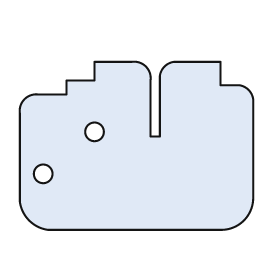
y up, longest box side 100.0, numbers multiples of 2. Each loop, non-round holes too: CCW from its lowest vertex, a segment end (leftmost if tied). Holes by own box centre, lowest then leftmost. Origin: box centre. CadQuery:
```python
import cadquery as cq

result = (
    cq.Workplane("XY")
    .moveTo(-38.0, -36.0)
    .lineTo(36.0, -36.0)
    .threePointArc((46.0, -32.0), (50.0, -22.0))
    .lineTo(50.0, 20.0)
    .threePointArc((48.0, 24.0), (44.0, 26.0))
    .lineTo(36.0, 26.0)
    .lineTo(36.0, 36.0)
    .lineTo(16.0, 36.0)
    .threePointArc((12.0, 34.0), (10.0, 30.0))
    .lineTo(10.0, 4.0)
    .lineTo(6.0, 4.0)
    .lineTo(6.0, 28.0)
    .threePointArc((4.0, 34.0), (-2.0, 36.0))
    .lineTo(-18.0, 36.0)
    .lineTo(-18.0, 28.0)
    .lineTo(-30.0, 28.0)
    .lineTo(-30.0, 22.0)
    .lineTo(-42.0, 22.0)
    .threePointArc((-48.0, 20.0), (-50.0, 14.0))
    .lineTo(-50.0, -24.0)
    .threePointArc((-46.0, -32.0), (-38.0, -36.0))
    .close()
    .moveTo(-40.0, -12.0)
    .circle(4.0)
    .moveTo(-18.0, 6.0)
    .circle(4.0)
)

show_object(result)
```